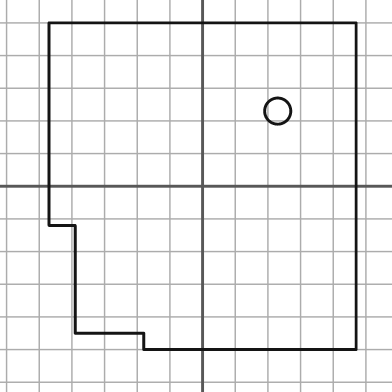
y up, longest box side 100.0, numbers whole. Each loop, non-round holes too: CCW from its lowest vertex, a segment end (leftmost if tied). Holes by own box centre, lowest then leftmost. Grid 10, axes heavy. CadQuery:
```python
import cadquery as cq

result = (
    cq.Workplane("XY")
    .moveTo(-18.0, -50.0)
    .lineTo(47.0, -50.0)
    .lineTo(47.0, 50.0)
    .lineTo(-47.0, 50.0)
    .lineTo(-47.0, -12.0)
    .lineTo(-39.0, -12.0)
    .lineTo(-39.0, -45.0)
    .lineTo(-18.0, -45.0)
    .close()
    .moveTo(23.0, 23.0)
    .circle(4.0)
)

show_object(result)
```